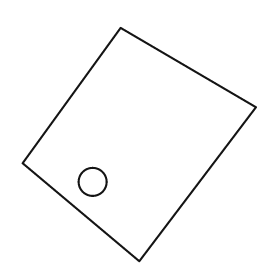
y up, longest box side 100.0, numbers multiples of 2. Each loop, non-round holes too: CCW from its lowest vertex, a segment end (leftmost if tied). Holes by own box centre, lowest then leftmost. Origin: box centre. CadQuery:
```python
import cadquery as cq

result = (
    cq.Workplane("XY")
    .moveTo(0.0, -50.0)
    .lineTo(50.0, 16.0)
    .lineTo(-8.0, 50.0)
    .lineTo(-50.0, -8.0)
    .close()
    .moveTo(-20.0, -16.0)
    .circle(6.0)
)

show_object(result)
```